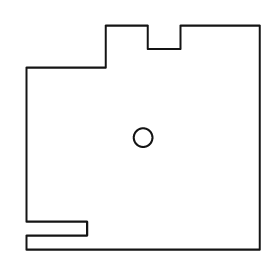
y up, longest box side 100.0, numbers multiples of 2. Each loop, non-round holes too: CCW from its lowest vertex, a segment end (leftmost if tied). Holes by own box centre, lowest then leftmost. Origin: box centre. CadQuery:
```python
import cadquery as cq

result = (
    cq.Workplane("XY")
    .moveTo(-50.0, -48.0)
    .lineTo(50.0, -48.0)
    .lineTo(50.0, 48.0)
    .lineTo(16.0, 48.0)
    .lineTo(16.0, 38.0)
    .lineTo(2.0, 38.0)
    .lineTo(2.0, 48.0)
    .lineTo(-16.0, 48.0)
    .lineTo(-16.0, 30.0)
    .lineTo(-50.0, 30.0)
    .lineTo(-50.0, -36.0)
    .lineTo(-24.0, -36.0)
    .lineTo(-24.0, -42.0)
    .lineTo(-50.0, -42.0)
    .close()
    .moveTo(0.0, 0.0)
    .circle(4.0)
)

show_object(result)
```